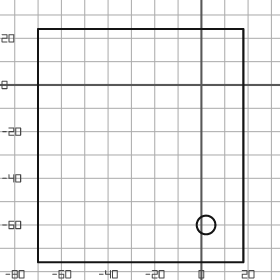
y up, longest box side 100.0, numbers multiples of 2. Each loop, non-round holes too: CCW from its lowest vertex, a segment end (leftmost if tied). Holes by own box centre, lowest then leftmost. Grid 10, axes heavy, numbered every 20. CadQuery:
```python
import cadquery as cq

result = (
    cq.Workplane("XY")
    .moveTo(-70.0, -76.0)
    .lineTo(18.0, -76.0)
    .lineTo(18.0, 24.0)
    .lineTo(-70.0, 24.0)
    .close()
    .moveTo(2.0, -60.0)
    .circle(4.0)
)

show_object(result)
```